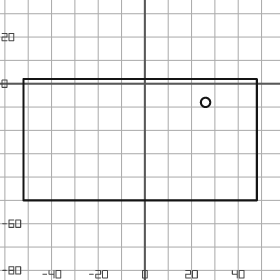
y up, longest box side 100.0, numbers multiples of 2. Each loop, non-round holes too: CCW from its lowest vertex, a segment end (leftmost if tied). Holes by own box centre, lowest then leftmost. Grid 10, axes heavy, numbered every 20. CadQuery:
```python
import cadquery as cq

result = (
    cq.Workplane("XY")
    .moveTo(-52.0, -50.0)
    .lineTo(48.0, -50.0)
    .lineTo(48.0, 2.0)
    .lineTo(-52.0, 2.0)
    .close()
    .moveTo(26.0, -8.0)
    .circle(2.0)
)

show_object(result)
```